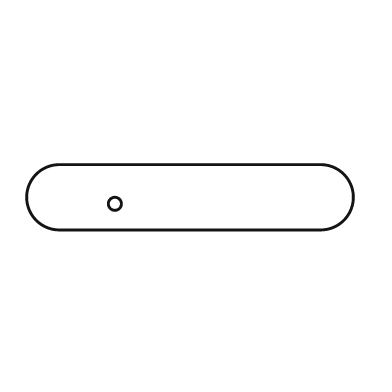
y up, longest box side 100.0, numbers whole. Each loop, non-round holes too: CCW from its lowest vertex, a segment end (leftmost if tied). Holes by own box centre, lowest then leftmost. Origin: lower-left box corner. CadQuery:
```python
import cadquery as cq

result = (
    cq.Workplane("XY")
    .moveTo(10.0, 0.0)
    .lineTo(90.0, 0.0)
    .threePointArc((100.0, 10.0), (90.0, 20.0))
    .lineTo(10.0, 20.0)
    .threePointArc((0.0, 10.0), (10.0, 0.0))
    .close()
    .moveTo(27.0, 8.0)
    .circle(2.0)
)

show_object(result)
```